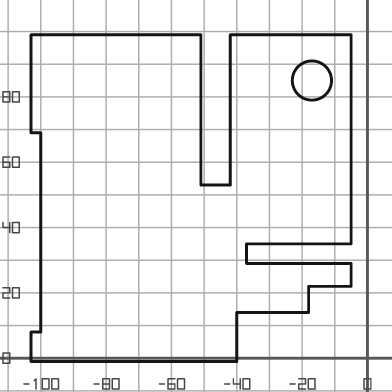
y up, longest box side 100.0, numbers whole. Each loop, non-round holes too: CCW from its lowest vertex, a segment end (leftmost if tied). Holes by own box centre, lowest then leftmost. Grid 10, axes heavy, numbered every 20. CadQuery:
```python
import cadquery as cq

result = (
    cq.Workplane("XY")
    .moveTo(-103.0, -1.0)
    .lineTo(-40.0, -1.0)
    .lineTo(-40.0, 14.0)
    .lineTo(-18.0, 14.0)
    .lineTo(-18.0, 22.0)
    .lineTo(-5.0, 22.0)
    .lineTo(-5.0, 29.0)
    .lineTo(-37.0, 29.0)
    .lineTo(-37.0, 35.0)
    .lineTo(-5.0, 35.0)
    .lineTo(-5.0, 99.0)
    .lineTo(-42.0, 99.0)
    .lineTo(-42.0, 53.0)
    .lineTo(-51.0, 53.0)
    .lineTo(-51.0, 99.0)
    .lineTo(-103.0, 99.0)
    .lineTo(-103.0, 69.0)
    .lineTo(-100.0, 69.0)
    .lineTo(-100.0, 8.0)
    .lineTo(-103.0, 8.0)
    .close()
    .moveTo(-17.0, 85.0)
    .circle(6.0)
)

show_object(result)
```